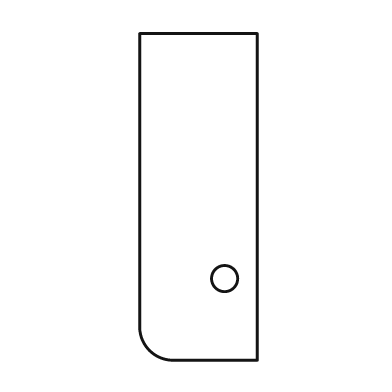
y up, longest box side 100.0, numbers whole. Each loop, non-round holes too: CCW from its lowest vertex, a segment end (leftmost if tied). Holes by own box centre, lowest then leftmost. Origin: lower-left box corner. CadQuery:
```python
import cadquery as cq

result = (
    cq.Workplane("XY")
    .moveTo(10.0, 0.0)
    .lineTo(36.0, 0.0)
    .lineTo(36.0, 100.0)
    .lineTo(0.0, 100.0)
    .lineTo(0.0, 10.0)
    .threePointArc((3.0, 3.0), (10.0, 0.0))
    .close()
    .moveTo(26.0, 25.0)
    .circle(4.0)
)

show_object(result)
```